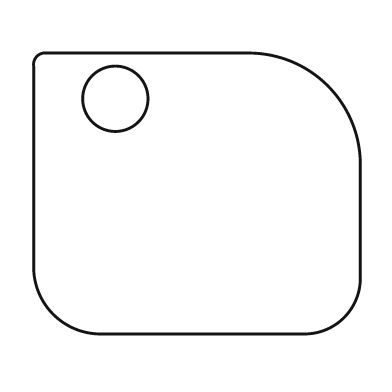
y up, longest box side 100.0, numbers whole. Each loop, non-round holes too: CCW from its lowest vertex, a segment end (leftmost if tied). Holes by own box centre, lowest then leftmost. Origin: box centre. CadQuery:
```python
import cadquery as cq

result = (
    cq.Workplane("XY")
    .moveTo(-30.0, -43.0)
    .lineTo(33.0, -43.0)
    .threePointArc((45.0, -38.0), (50.0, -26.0))
    .lineTo(50.0, 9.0)
    .threePointArc((40.0, 33.0), (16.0, 43.0))
    .lineTo(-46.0, 43.0)
    .threePointArc((-49.0, 42.0), (-50.0, 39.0))
    .lineTo(-50.0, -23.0)
    .threePointArc((-44.0, -37.0), (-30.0, -43.0))
    .close()
    .moveTo(-25.0, 29.0)
    .circle(10.0)
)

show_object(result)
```